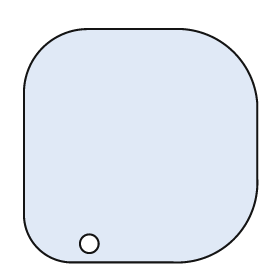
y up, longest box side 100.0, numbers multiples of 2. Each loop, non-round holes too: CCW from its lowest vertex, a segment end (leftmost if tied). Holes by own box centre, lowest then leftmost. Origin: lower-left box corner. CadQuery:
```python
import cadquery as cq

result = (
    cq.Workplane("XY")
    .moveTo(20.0, 0.0)
    .lineTo(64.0, 0.0)
    .threePointArc((90.0, 10.0), (100.0, 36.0))
    .lineTo(100.0, 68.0)
    .threePointArc((90.0, 90.0), (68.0, 100.0))
    .lineTo(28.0, 100.0)
    .threePointArc((8.0, 92.0), (0.0, 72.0))
    .lineTo(0.0, 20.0)
    .threePointArc((6.0, 6.0), (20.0, 0.0))
    .close()
    .moveTo(28.0, 8.0)
    .circle(4.0)
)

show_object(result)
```